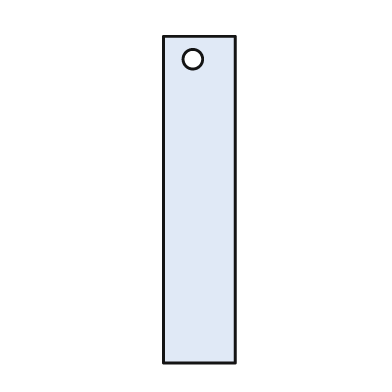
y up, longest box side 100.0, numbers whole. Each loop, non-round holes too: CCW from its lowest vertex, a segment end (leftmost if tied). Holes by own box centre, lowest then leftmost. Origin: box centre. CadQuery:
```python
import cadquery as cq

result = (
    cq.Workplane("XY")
    .moveTo(-11.0, -50.0)
    .lineTo(11.0, -50.0)
    .lineTo(11.0, 50.0)
    .lineTo(-11.0, 50.0)
    .close()
    .moveTo(-2.0, 43.0)
    .circle(3.0)
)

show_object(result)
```